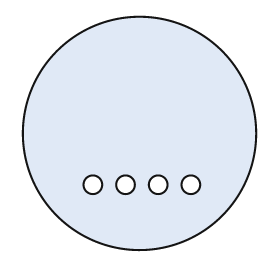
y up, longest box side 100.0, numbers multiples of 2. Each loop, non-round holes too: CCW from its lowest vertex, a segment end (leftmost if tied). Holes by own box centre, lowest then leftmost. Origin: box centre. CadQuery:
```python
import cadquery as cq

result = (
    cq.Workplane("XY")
    .moveTo(0.0, 0.0)
    .circle(50.0)
    .moveTo(-20.0, -22.0)
    .circle(4.0)
    .moveTo(-6.0, -22.0)
    .circle(4.0)
    .moveTo(8.0, -22.0)
    .circle(4.0)
    .moveTo(22.0, -22.0)
    .circle(4.0)
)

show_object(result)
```